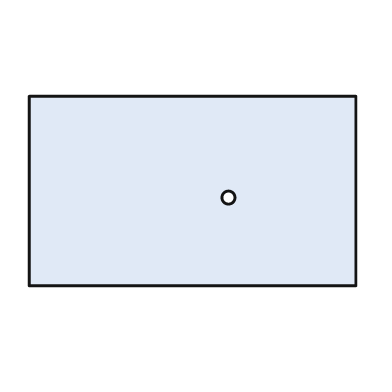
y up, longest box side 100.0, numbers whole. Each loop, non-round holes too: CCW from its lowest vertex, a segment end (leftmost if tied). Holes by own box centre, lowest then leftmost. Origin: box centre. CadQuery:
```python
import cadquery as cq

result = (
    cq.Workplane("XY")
    .moveTo(-50.0, -29.0)
    .lineTo(50.0, -29.0)
    .lineTo(50.0, 29.0)
    .lineTo(-50.0, 29.0)
    .close()
    .moveTo(11.0, -2.0)
    .circle(2.0)
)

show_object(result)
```